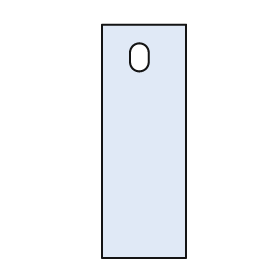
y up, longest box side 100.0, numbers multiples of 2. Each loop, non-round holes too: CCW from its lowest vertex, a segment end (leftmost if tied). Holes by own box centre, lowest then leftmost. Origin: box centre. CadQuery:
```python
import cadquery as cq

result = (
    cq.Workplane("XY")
    .moveTo(-18.0, -50.0)
    .lineTo(18.0, -50.0)
    .lineTo(18.0, 50.0)
    .lineTo(-18.0, 50.0)
    .close()
    .moveTo(-6.0, 34.0)
    .threePointArc((-2.0, 30.0), (2.0, 34.0))
    .lineTo(2.0, 38.0)
    .threePointArc((-2.0, 42.0), (-6.0, 38.0))
    .close()
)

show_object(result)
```